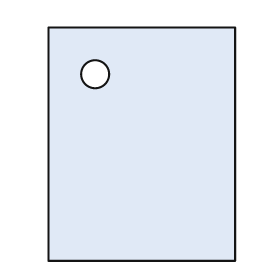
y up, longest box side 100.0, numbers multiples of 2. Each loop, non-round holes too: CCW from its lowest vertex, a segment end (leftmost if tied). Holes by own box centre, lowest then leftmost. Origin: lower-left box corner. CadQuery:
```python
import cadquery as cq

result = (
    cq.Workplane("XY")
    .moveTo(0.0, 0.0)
    .lineTo(80.0, 0.0)
    .lineTo(80.0, 100.0)
    .lineTo(0.0, 100.0)
    .close()
    .moveTo(20.0, 80.0)
    .circle(6.0)
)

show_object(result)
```